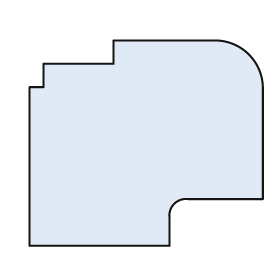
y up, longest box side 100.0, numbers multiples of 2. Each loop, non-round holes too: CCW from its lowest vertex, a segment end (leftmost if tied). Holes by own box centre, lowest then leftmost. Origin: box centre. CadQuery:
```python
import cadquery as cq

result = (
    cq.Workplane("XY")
    .moveTo(-50.0, -44.0)
    .lineTo(10.0, -44.0)
    .lineTo(10.0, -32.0)
    .threePointArc((12.0, -26.0), (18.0, -24.0))
    .lineTo(50.0, -24.0)
    .lineTo(50.0, 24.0)
    .threePointArc((44.0, 38.0), (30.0, 44.0))
    .lineTo(-14.0, 44.0)
    .lineTo(-14.0, 34.0)
    .lineTo(-44.0, 34.0)
    .lineTo(-44.0, 24.0)
    .lineTo(-50.0, 24.0)
    .close()
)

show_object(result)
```